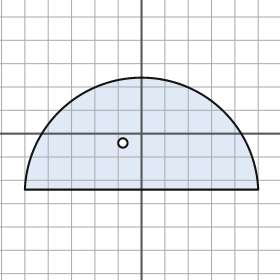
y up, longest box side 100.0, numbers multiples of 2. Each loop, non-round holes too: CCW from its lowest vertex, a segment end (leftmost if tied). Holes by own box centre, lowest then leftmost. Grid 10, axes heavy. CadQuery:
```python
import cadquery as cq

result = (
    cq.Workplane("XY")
    .moveTo(-50.0, -24.0)
    .lineTo(50.0, -24.0)
    .threePointArc((0.0, 24.0), (-50.0, -24.0))
    .close()
    .moveTo(-8.0, -4.0)
    .circle(2.0)
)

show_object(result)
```